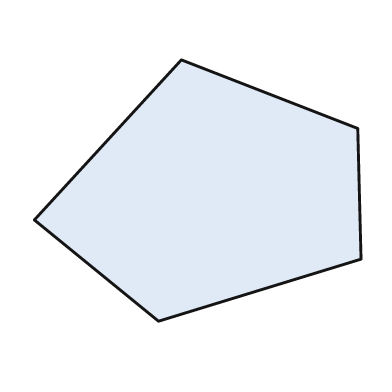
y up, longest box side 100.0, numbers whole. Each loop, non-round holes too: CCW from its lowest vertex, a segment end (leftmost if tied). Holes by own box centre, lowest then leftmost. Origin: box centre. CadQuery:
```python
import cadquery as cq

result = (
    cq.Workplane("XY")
    .moveTo(-12.0, -40.0)
    .lineTo(50.0, -21.0)
    .lineTo(49.0, 19.0)
    .lineTo(-5.0, 40.0)
    .lineTo(-50.0, -9.0)
    .close()
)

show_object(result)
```